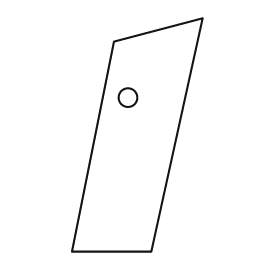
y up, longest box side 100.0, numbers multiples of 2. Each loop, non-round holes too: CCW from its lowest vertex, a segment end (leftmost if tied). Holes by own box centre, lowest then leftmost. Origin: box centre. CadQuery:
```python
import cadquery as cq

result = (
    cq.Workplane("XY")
    .moveTo(-28.0, -50.0)
    .lineTo(6.0, -50.0)
    .lineTo(28.0, 50.0)
    .lineTo(-10.0, 40.0)
    .close()
    .moveTo(-4.0, 16.0)
    .circle(4.0)
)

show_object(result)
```